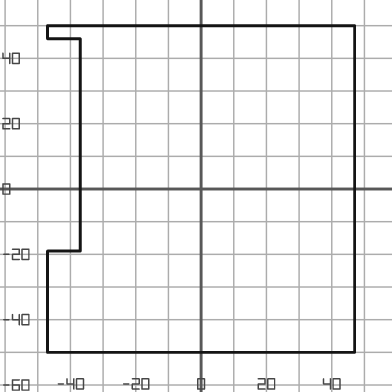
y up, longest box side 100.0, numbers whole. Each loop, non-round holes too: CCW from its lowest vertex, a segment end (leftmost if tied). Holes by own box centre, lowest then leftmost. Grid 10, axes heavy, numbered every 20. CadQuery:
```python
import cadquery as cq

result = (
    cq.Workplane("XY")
    .moveTo(-47.0, -50.0)
    .lineTo(47.0, -50.0)
    .lineTo(47.0, 50.0)
    .lineTo(-47.0, 50.0)
    .lineTo(-47.0, 46.0)
    .lineTo(-37.0, 46.0)
    .lineTo(-37.0, -19.0)
    .lineTo(-47.0, -19.0)
    .close()
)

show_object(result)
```